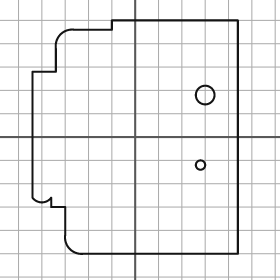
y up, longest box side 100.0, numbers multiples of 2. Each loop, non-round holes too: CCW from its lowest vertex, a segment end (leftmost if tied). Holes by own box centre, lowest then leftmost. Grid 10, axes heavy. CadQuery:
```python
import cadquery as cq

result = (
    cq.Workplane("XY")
    .moveTo(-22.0, -50.0)
    .lineTo(44.0, -50.0)
    .lineTo(44.0, 50.0)
    .lineTo(-10.0, 50.0)
    .lineTo(-10.0, 46.0)
    .lineTo(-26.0, 46.0)
    .threePointArc((-32.0, 44.0), (-34.0, 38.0))
    .lineTo(-34.0, 28.0)
    .lineTo(-44.0, 28.0)
    .lineTo(-44.0, -26.0)
    .threePointArc((-40.0, -28.0), (-36.0, -26.0))
    .lineTo(-36.0, -30.0)
    .lineTo(-30.0, -30.0)
    .lineTo(-30.0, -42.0)
    .threePointArc((-28.0, -48.0), (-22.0, -50.0))
    .close()
    .moveTo(28.0, -12.0)
    .circle(2.0)
    .moveTo(30.0, 18.0)
    .circle(4.0)
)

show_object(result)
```